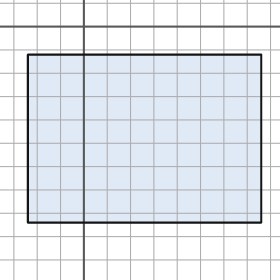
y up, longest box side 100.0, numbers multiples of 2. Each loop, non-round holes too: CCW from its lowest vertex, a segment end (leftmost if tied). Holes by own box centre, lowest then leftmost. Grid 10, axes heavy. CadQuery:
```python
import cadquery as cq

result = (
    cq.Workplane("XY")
    .moveTo(-24.0, -84.0)
    .lineTo(76.0, -84.0)
    .lineTo(76.0, -12.0)
    .lineTo(-24.0, -12.0)
    .close()
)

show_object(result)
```